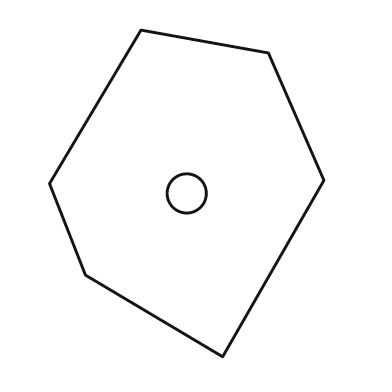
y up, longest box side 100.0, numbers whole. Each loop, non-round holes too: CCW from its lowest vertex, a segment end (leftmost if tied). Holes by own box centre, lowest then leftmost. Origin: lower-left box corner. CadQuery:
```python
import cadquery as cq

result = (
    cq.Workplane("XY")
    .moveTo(53.0, 0.0)
    .lineTo(84.0, 54.0)
    .lineTo(67.0, 93.0)
    .lineTo(28.0, 100.0)
    .lineTo(0.0, 53.0)
    .lineTo(11.0, 25.0)
    .close()
    .moveTo(42.0, 50.0)
    .circle(6.0)
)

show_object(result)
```